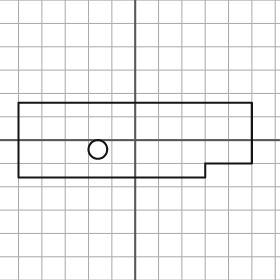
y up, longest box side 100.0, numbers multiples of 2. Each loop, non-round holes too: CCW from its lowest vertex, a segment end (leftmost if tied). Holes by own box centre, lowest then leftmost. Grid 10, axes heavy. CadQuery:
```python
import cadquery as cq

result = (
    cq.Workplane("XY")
    .moveTo(-50.0, -16.0)
    .lineTo(30.0, -16.0)
    .lineTo(30.0, -10.0)
    .lineTo(50.0, -10.0)
    .lineTo(50.0, 16.0)
    .lineTo(-50.0, 16.0)
    .close()
    .moveTo(-16.0, -4.0)
    .circle(4.0)
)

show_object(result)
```